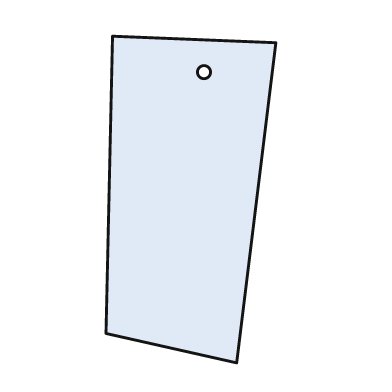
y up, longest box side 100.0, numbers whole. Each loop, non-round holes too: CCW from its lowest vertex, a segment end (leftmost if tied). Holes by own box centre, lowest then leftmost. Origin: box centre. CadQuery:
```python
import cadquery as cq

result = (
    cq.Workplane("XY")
    .moveTo(14.0, -50.0)
    .lineTo(26.0, 48.0)
    .lineTo(-24.0, 50.0)
    .lineTo(-26.0, -41.0)
    .close()
    .moveTo(4.0, 39.0)
    .circle(2.0)
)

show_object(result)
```